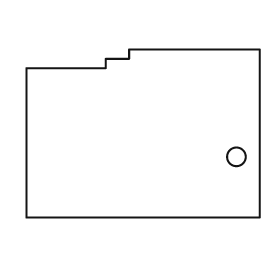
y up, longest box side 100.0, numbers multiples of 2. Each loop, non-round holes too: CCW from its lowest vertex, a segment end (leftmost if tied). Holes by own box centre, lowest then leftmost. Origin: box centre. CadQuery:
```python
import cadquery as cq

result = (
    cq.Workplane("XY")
    .moveTo(-50.0, -36.0)
    .lineTo(50.0, -36.0)
    .lineTo(50.0, 36.0)
    .lineTo(-6.0, 36.0)
    .lineTo(-6.0, 32.0)
    .lineTo(-16.0, 32.0)
    .lineTo(-16.0, 28.0)
    .lineTo(-50.0, 28.0)
    .close()
    .moveTo(40.0, -10.0)
    .circle(4.0)
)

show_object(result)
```